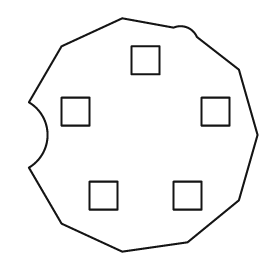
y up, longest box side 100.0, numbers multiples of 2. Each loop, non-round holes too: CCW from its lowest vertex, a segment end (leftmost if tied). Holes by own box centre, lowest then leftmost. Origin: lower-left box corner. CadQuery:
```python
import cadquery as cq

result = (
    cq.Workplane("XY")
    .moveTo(40.0, 0.0)
    .lineTo(68.0, 4.0)
    .lineTo(90.0, 22.0)
    .lineTo(98.0, 50.0)
    .lineTo(90.0, 78.0)
    .lineTo(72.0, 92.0)
    .threePointArc((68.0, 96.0), (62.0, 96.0))
    .lineTo(40.0, 100.0)
    .lineTo(14.0, 88.0)
    .lineTo(0.0, 64.0)
    .threePointArc((8.0, 50.0), (0.0, 36.0))
    .lineTo(14.0, 12.0)
    .close()
    .moveTo(26.0, 18.0)
    .lineTo(38.0, 18.0)
    .lineTo(38.0, 30.0)
    .lineTo(26.0, 30.0)
    .close()
    .moveTo(62.0, 18.0)
    .lineTo(74.0, 18.0)
    .lineTo(74.0, 30.0)
    .lineTo(62.0, 30.0)
    .close()
    .moveTo(14.0, 54.0)
    .lineTo(26.0, 54.0)
    .lineTo(26.0, 66.0)
    .lineTo(14.0, 66.0)
    .close()
    .moveTo(74.0, 54.0)
    .lineTo(86.0, 54.0)
    .lineTo(86.0, 66.0)
    .lineTo(74.0, 66.0)
    .close()
    .moveTo(44.0, 76.0)
    .lineTo(56.0, 76.0)
    .lineTo(56.0, 88.0)
    .lineTo(44.0, 88.0)
    .close()
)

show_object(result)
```